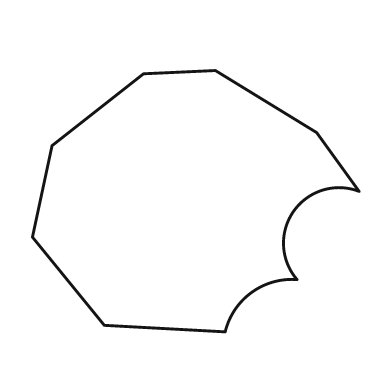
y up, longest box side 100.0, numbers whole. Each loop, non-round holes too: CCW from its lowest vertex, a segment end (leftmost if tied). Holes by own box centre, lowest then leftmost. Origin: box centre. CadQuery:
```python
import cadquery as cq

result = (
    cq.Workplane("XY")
    .moveTo(9.0, -40.0)
    .threePointArc((17.0, -28.0), (31.0, -24.0))
    .threePointArc((30.0, -3.0), (50.0, 3.0))
    .lineTo(37.0, 21.0)
    .lineTo(6.0, 40.0)
    .lineTo(-16.0, 39.0)
    .lineTo(-44.0, 17.0)
    .lineTo(-50.0, -11.0)
    .lineTo(-28.0, -38.0)
    .close()
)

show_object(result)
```